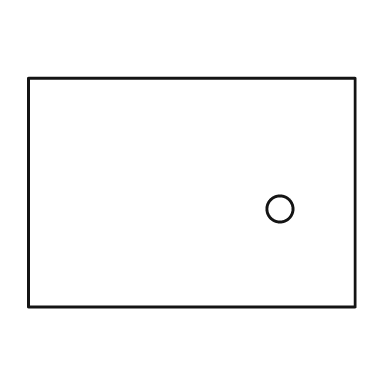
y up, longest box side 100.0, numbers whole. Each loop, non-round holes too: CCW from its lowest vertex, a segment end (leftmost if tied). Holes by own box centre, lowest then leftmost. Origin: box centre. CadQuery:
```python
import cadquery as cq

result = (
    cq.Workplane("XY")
    .moveTo(-50.0, -35.0)
    .lineTo(50.0, -35.0)
    .lineTo(50.0, 35.0)
    .lineTo(-50.0, 35.0)
    .close()
    .moveTo(27.0, -5.0)
    .circle(4.0)
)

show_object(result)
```